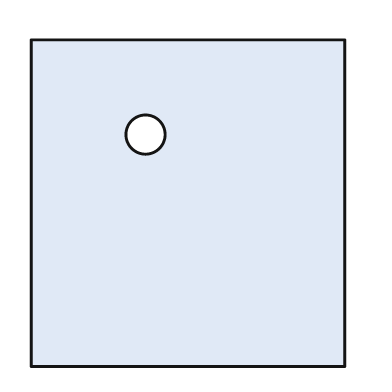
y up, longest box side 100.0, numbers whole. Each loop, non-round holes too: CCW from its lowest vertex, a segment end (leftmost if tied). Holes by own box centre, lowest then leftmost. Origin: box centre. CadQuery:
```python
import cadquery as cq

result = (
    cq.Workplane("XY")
    .moveTo(-48.0, -50.0)
    .lineTo(48.0, -50.0)
    .lineTo(48.0, 50.0)
    .lineTo(-48.0, 50.0)
    .close()
    .moveTo(-13.0, 21.0)
    .circle(6.0)
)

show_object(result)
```